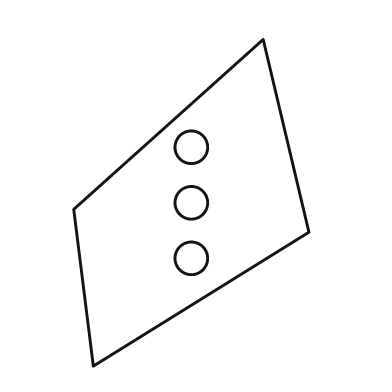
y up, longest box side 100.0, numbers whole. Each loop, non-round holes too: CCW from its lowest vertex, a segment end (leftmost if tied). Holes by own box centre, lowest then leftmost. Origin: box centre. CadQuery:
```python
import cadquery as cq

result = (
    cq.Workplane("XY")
    .moveTo(-30.0, -50.0)
    .lineTo(36.0, -9.0)
    .lineTo(22.0, 50.0)
    .lineTo(-36.0, -2.0)
    .close()
    .moveTo(0.0, -17.0)
    .circle(5.0)
    .moveTo(0.0, 0.0)
    .circle(5.0)
    .moveTo(0.0, 17.0)
    .circle(5.0)
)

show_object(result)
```